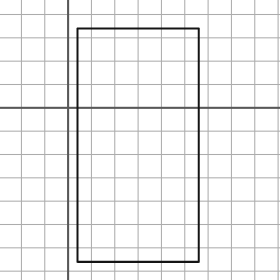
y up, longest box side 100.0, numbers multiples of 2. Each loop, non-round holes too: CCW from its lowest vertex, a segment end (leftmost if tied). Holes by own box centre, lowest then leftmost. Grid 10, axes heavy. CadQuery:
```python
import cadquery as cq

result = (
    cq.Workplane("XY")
    .moveTo(4.0, -66.0)
    .lineTo(56.0, -66.0)
    .lineTo(56.0, 34.0)
    .lineTo(4.0, 34.0)
    .close()
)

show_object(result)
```